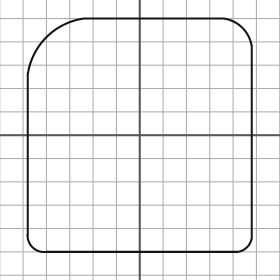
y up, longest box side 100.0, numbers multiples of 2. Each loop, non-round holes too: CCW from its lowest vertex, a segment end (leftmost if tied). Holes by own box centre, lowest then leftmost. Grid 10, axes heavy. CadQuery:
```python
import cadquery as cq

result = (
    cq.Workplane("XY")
    .moveTo(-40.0, -50.0)
    .lineTo(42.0, -50.0)
    .threePointArc((46.0, -48.0), (48.0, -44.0))
    .lineTo(48.0, 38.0)
    .threePointArc((44.0, 46.0), (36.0, 50.0))
    .lineTo(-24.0, 50.0)
    .threePointArc((-40.0, 42.0), (-48.0, 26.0))
    .lineTo(-48.0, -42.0)
    .threePointArc((-46.0, -48.0), (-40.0, -50.0))
    .close()
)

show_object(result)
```